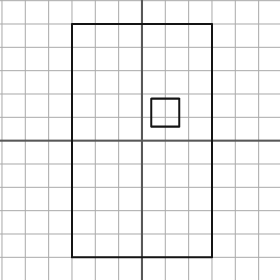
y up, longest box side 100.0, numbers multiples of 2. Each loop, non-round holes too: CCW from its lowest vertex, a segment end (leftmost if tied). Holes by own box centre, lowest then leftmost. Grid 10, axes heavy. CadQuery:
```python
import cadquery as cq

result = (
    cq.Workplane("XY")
    .moveTo(-30.0, -50.0)
    .lineTo(30.0, -50.0)
    .lineTo(30.0, 50.0)
    .lineTo(-30.0, 50.0)
    .close()
    .moveTo(4.0, 6.0)
    .lineTo(16.0, 6.0)
    .lineTo(16.0, 18.0)
    .lineTo(4.0, 18.0)
    .close()
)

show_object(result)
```